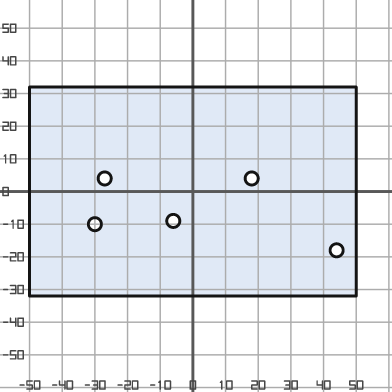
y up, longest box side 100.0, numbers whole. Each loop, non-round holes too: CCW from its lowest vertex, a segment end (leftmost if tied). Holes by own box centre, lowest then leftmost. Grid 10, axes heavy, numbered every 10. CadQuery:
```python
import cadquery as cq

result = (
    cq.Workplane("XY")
    .moveTo(-50.0, -32.0)
    .lineTo(50.0, -32.0)
    .lineTo(50.0, 32.0)
    .lineTo(-50.0, 32.0)
    .close()
    .moveTo(44.0, -18.0)
    .circle(2.0)
    .moveTo(-30.0, -10.0)
    .circle(2.0)
    .moveTo(-6.0, -9.0)
    .circle(2.0)
    .moveTo(-27.0, 4.0)
    .circle(2.0)
    .moveTo(18.0, 4.0)
    .circle(2.0)
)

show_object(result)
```